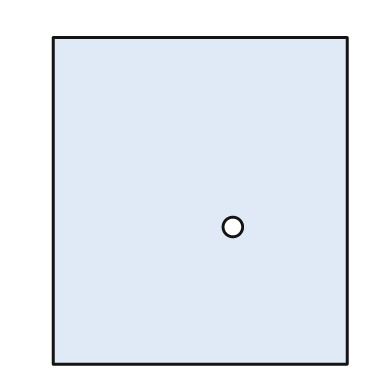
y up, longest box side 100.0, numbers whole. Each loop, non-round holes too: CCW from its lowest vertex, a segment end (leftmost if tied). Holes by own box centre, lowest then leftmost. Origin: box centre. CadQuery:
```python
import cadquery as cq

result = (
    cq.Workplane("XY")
    .moveTo(-45.0, -50.0)
    .lineTo(45.0, -50.0)
    .lineTo(45.0, 50.0)
    .lineTo(-45.0, 50.0)
    .close()
    .moveTo(10.0, -8.0)
    .circle(3.0)
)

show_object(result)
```